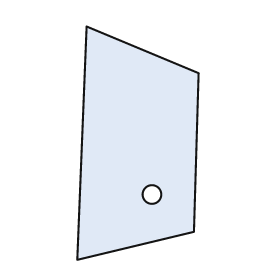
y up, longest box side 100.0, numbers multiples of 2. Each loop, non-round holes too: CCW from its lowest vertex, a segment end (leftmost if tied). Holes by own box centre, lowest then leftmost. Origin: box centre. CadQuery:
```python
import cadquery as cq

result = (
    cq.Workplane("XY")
    .moveTo(-26.0, -50.0)
    .lineTo(24.0, -38.0)
    .lineTo(26.0, 30.0)
    .lineTo(-22.0, 50.0)
    .close()
    .moveTo(6.0, -22.0)
    .circle(4.0)
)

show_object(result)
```